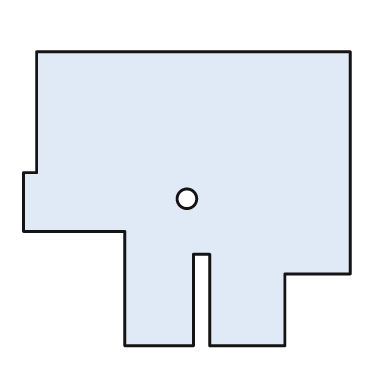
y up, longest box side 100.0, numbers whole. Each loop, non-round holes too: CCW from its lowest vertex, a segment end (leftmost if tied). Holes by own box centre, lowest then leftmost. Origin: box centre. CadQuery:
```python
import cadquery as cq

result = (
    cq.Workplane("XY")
    .moveTo(-19.0, -45.0)
    .lineTo(2.0, -45.0)
    .lineTo(2.0, -17.0)
    .lineTo(7.0, -17.0)
    .lineTo(7.0, -45.0)
    .lineTo(30.0, -45.0)
    .lineTo(30.0, -23.0)
    .lineTo(50.0, -23.0)
    .lineTo(50.0, 45.0)
    .lineTo(-46.0, 45.0)
    .lineTo(-46.0, 8.0)
    .lineTo(-50.0, 8.0)
    .lineTo(-50.0, -10.0)
    .lineTo(-19.0, -10.0)
    .close()
    .moveTo(0.0, 0.0)
    .circle(3.0)
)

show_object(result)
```